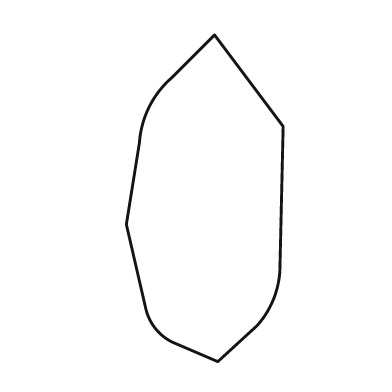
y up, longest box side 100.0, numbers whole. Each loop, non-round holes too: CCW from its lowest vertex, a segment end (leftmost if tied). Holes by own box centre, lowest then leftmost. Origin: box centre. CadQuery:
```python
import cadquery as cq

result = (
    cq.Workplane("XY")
    .moveTo(4.0, -50.0)
    .lineTo(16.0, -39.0)
    .threePointArc((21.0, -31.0), (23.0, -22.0))
    .lineTo(24.0, 22.0)
    .lineTo(3.0, 50.0)
    .lineTo(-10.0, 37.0)
    .threePointArc((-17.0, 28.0), (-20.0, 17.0))
    .lineTo(-24.0, -8.0)
    .lineTo(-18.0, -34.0)
    .threePointArc((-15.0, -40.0), (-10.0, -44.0))
    .close()
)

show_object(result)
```